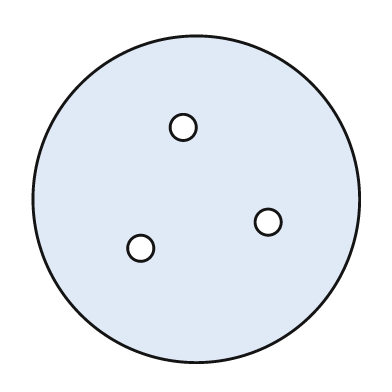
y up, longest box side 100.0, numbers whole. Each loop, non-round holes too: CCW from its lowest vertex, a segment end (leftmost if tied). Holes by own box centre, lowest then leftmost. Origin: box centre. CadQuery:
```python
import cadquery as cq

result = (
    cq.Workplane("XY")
    .moveTo(0.0, 0.0)
    .circle(50.0)
    .moveTo(-17.0, -15.0)
    .circle(4.0)
    .moveTo(22.0, -7.0)
    .circle(4.0)
    .moveTo(-4.0, 22.0)
    .circle(4.0)
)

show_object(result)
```